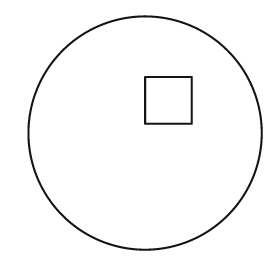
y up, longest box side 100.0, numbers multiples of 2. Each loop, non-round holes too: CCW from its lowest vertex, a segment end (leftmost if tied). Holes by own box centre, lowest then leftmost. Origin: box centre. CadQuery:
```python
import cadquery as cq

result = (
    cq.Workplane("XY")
    .moveTo(0.0, 0.0)
    .circle(50.0)
    .moveTo(0.0, 4.0)
    .lineTo(20.0, 4.0)
    .lineTo(20.0, 24.0)
    .lineTo(0.0, 24.0)
    .close()
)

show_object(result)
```